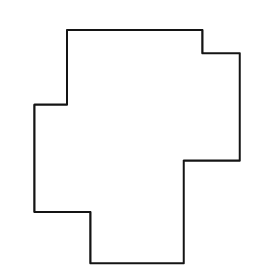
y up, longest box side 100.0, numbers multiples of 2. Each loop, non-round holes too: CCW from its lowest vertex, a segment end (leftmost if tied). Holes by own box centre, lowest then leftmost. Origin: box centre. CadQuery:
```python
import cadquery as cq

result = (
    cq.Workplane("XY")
    .moveTo(-20.0, -50.0)
    .lineTo(20.0, -50.0)
    .lineTo(20.0, -6.0)
    .lineTo(44.0, -6.0)
    .lineTo(44.0, 40.0)
    .lineTo(28.0, 40.0)
    .lineTo(28.0, 50.0)
    .lineTo(-30.0, 50.0)
    .lineTo(-30.0, 18.0)
    .lineTo(-44.0, 18.0)
    .lineTo(-44.0, -28.0)
    .lineTo(-20.0, -28.0)
    .close()
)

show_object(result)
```